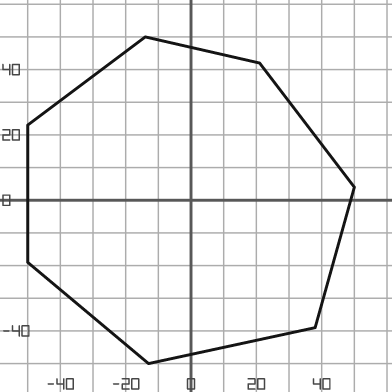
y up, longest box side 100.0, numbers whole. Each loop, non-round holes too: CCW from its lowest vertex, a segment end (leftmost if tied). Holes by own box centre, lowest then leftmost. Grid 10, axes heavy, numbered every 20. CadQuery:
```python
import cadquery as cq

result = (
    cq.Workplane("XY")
    .moveTo(-13.0, -50.0)
    .lineTo(38.0, -39.0)
    .lineTo(50.0, 4.0)
    .lineTo(21.0, 42.0)
    .lineTo(-14.0, 50.0)
    .lineTo(-50.0, 23.0)
    .lineTo(-50.0, -19.0)
    .close()
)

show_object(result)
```